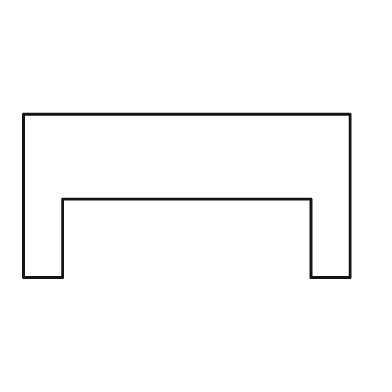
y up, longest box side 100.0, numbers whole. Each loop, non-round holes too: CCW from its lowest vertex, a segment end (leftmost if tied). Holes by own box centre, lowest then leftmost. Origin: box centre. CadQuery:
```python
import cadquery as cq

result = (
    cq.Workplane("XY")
    .moveTo(-50.0, -25.0)
    .lineTo(-38.0, -25.0)
    .lineTo(-38.0, -1.0)
    .lineTo(38.0, -1.0)
    .lineTo(38.0, -25.0)
    .lineTo(50.0, -25.0)
    .lineTo(50.0, 25.0)
    .lineTo(-50.0, 25.0)
    .close()
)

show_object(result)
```